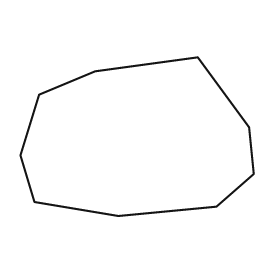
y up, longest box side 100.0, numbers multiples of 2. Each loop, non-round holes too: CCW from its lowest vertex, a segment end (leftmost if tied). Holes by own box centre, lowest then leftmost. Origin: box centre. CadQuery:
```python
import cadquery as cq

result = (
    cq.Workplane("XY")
    .moveTo(-8.0, -34.0)
    .lineTo(34.0, -30.0)
    .lineTo(50.0, -16.0)
    .lineTo(48.0, 4.0)
    .lineTo(26.0, 34.0)
    .lineTo(-18.0, 28.0)
    .lineTo(-42.0, 18.0)
    .lineTo(-50.0, -8.0)
    .lineTo(-44.0, -28.0)
    .close()
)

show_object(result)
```